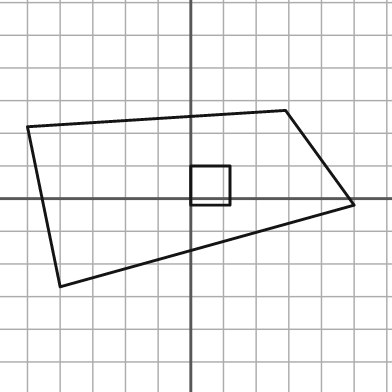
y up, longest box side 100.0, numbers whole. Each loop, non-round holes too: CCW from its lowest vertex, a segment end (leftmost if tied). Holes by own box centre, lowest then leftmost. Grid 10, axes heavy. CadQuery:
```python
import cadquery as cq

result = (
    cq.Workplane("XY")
    .moveTo(-40.0, -27.0)
    .lineTo(50.0, -2.0)
    .lineTo(29.0, 27.0)
    .lineTo(-50.0, 22.0)
    .close()
    .moveTo(0.0, -2.0)
    .lineTo(12.0, -2.0)
    .lineTo(12.0, 10.0)
    .lineTo(0.0, 10.0)
    .close()
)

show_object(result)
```